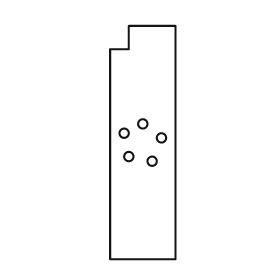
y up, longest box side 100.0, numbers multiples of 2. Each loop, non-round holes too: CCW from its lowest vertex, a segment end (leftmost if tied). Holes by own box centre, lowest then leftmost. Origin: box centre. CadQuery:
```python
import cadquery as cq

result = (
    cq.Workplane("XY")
    .moveTo(-14.0, -50.0)
    .lineTo(14.0, -50.0)
    .lineTo(14.0, 50.0)
    .lineTo(-6.0, 50.0)
    .lineTo(-6.0, 40.0)
    .lineTo(-14.0, 40.0)
    .close()
    .moveTo(4.0, -8.0)
    .circle(2.0)
    .moveTo(-6.0, -6.0)
    .circle(2.0)
    .moveTo(8.0, 2.0)
    .circle(2.0)
    .moveTo(-8.0, 4.0)
    .circle(2.0)
    .moveTo(0.0, 8.0)
    .circle(2.0)
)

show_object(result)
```